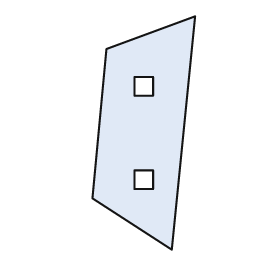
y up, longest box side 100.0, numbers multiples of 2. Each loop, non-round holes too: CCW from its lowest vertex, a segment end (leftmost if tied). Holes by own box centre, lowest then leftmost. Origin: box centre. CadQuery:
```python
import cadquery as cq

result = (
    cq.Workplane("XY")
    .moveTo(12.0, -50.0)
    .lineTo(22.0, 50.0)
    .lineTo(-16.0, 36.0)
    .lineTo(-22.0, -28.0)
    .close()
    .moveTo(-4.0, -24.0)
    .lineTo(4.0, -24.0)
    .lineTo(4.0, -16.0)
    .lineTo(-4.0, -16.0)
    .close()
    .moveTo(-4.0, 16.0)
    .lineTo(4.0, 16.0)
    .lineTo(4.0, 24.0)
    .lineTo(-4.0, 24.0)
    .close()
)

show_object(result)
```